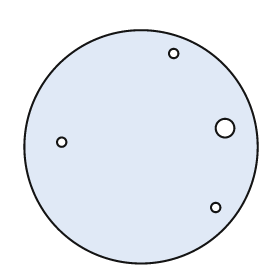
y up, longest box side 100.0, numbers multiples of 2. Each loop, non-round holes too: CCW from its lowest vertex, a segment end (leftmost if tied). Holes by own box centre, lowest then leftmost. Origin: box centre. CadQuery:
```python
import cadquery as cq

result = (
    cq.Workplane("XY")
    .moveTo(0.0, 0.0)
    .circle(50.0)
    .moveTo(32.0, -26.0)
    .circle(2.0)
    .moveTo(-34.0, 2.0)
    .circle(2.0)
    .moveTo(36.0, 8.0)
    .circle(4.0)
    .moveTo(14.0, 40.0)
    .circle(2.0)
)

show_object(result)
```